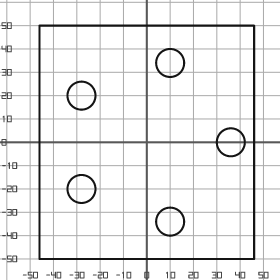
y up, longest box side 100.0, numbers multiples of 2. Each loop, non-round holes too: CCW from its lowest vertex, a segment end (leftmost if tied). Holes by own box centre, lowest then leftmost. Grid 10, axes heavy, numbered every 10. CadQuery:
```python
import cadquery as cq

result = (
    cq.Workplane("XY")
    .moveTo(-46.0, -50.0)
    .lineTo(46.0, -50.0)
    .lineTo(46.0, 50.0)
    .lineTo(-46.0, 50.0)
    .close()
    .moveTo(10.0, -34.0)
    .circle(6.0)
    .moveTo(-28.0, -20.0)
    .circle(6.0)
    .moveTo(36.0, 0.0)
    .circle(6.0)
    .moveTo(-28.0, 20.0)
    .circle(6.0)
    .moveTo(10.0, 34.0)
    .circle(6.0)
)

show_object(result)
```